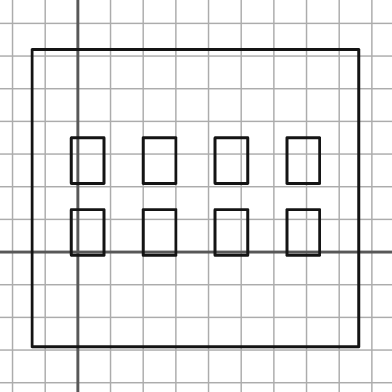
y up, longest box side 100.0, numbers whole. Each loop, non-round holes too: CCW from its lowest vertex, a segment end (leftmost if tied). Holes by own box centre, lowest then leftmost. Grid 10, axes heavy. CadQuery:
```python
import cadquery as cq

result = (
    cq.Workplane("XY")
    .moveTo(-14.0, -29.0)
    .lineTo(86.0, -29.0)
    .lineTo(86.0, 62.0)
    .lineTo(-14.0, 62.0)
    .close()
    .moveTo(-2.0, -1.0)
    .lineTo(8.0, -1.0)
    .lineTo(8.0, 13.0)
    .lineTo(-2.0, 13.0)
    .close()
    .moveTo(20.0, -1.0)
    .lineTo(30.0, -1.0)
    .lineTo(30.0, 13.0)
    .lineTo(20.0, 13.0)
    .close()
    .moveTo(42.0, -1.0)
    .lineTo(52.0, -1.0)
    .lineTo(52.0, 13.0)
    .lineTo(42.0, 13.0)
    .close()
    .moveTo(64.0, -1.0)
    .lineTo(74.0, -1.0)
    .lineTo(74.0, 13.0)
    .lineTo(64.0, 13.0)
    .close()
    .moveTo(-2.0, 21.0)
    .lineTo(8.0, 21.0)
    .lineTo(8.0, 35.0)
    .lineTo(-2.0, 35.0)
    .close()
    .moveTo(20.0, 21.0)
    .lineTo(30.0, 21.0)
    .lineTo(30.0, 35.0)
    .lineTo(20.0, 35.0)
    .close()
    .moveTo(42.0, 21.0)
    .lineTo(52.0, 21.0)
    .lineTo(52.0, 35.0)
    .lineTo(42.0, 35.0)
    .close()
    .moveTo(64.0, 21.0)
    .lineTo(74.0, 21.0)
    .lineTo(74.0, 35.0)
    .lineTo(64.0, 35.0)
    .close()
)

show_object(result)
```